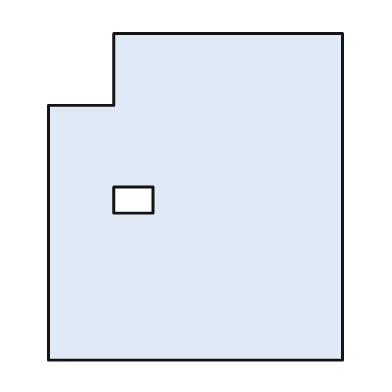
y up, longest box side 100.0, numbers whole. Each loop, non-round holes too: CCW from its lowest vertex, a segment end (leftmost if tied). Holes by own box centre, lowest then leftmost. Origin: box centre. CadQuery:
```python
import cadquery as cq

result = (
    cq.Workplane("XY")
    .moveTo(-45.0, -50.0)
    .lineTo(45.0, -50.0)
    .lineTo(45.0, 50.0)
    .lineTo(-25.0, 50.0)
    .lineTo(-25.0, 28.0)
    .lineTo(-45.0, 28.0)
    .close()
    .moveTo(-25.0, -5.0)
    .lineTo(-13.0, -5.0)
    .lineTo(-13.0, 3.0)
    .lineTo(-25.0, 3.0)
    .close()
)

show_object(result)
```